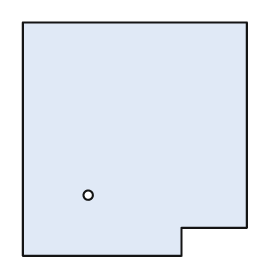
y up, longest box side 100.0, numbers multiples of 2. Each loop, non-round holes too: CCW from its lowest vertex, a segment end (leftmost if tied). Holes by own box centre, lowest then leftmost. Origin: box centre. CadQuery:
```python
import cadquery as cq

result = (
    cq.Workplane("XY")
    .moveTo(-48.0, -50.0)
    .lineTo(20.0, -50.0)
    .lineTo(20.0, -38.0)
    .lineTo(48.0, -38.0)
    .lineTo(48.0, 50.0)
    .lineTo(-48.0, 50.0)
    .close()
    .moveTo(-20.0, -24.0)
    .circle(2.0)
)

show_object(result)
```